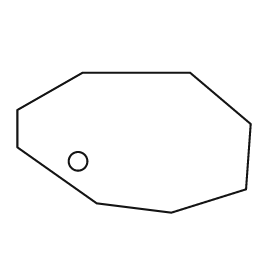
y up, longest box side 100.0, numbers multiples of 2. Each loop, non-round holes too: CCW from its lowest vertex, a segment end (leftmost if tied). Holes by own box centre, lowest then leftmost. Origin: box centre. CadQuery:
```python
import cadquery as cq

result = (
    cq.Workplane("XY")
    .moveTo(16.0, -30.0)
    .lineTo(48.0, -20.0)
    .lineTo(50.0, 8.0)
    .lineTo(24.0, 30.0)
    .lineTo(-22.0, 30.0)
    .lineTo(-50.0, 14.0)
    .lineTo(-50.0, -2.0)
    .lineTo(-16.0, -26.0)
    .close()
    .moveTo(-24.0, -8.0)
    .circle(4.0)
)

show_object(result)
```